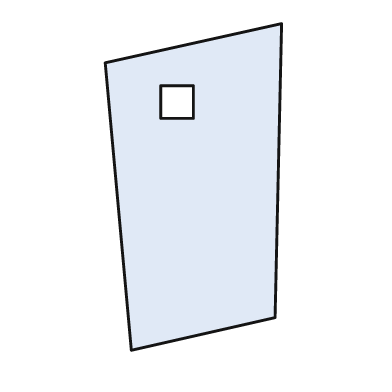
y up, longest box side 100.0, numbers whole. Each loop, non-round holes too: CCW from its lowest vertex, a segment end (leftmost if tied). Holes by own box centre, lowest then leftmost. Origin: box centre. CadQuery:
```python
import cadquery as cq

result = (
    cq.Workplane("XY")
    .moveTo(-19.0, -50.0)
    .lineTo(25.0, -40.0)
    .lineTo(27.0, 50.0)
    .lineTo(-27.0, 38.0)
    .close()
    .moveTo(-10.0, 21.0)
    .lineTo(0.0, 21.0)
    .lineTo(0.0, 31.0)
    .lineTo(-10.0, 31.0)
    .close()
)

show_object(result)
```